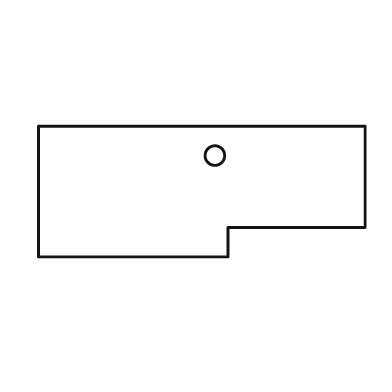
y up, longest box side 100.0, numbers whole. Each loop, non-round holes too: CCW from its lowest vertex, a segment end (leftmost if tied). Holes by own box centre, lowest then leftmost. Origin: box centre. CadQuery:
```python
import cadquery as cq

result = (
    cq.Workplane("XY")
    .moveTo(-50.0, -20.0)
    .lineTo(8.0, -20.0)
    .lineTo(8.0, -11.0)
    .lineTo(50.0, -11.0)
    .lineTo(50.0, 20.0)
    .lineTo(-50.0, 20.0)
    .close()
    .moveTo(4.0, 11.0)
    .circle(3.0)
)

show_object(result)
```